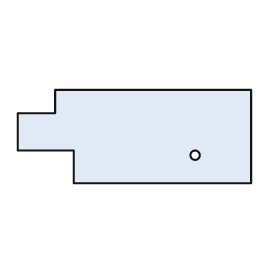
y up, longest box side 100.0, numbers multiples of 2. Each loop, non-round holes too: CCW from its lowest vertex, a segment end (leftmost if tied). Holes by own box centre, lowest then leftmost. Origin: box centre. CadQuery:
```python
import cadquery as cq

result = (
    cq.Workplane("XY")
    .moveTo(-26.0, -20.0)
    .lineTo(50.0, -20.0)
    .lineTo(50.0, 20.0)
    .lineTo(-34.0, 20.0)
    .lineTo(-34.0, 10.0)
    .lineTo(-50.0, 10.0)
    .lineTo(-50.0, -6.0)
    .lineTo(-26.0, -6.0)
    .close()
    .moveTo(26.0, -8.0)
    .circle(2.0)
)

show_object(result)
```